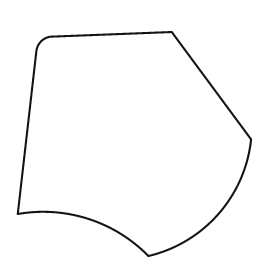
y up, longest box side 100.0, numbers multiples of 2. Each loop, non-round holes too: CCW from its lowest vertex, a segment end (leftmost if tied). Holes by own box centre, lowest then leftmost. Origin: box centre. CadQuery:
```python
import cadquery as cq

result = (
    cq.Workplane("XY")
    .moveTo(6.0, -48.0)
    .threePointArc((36.0, -30.0), (50.0, 2.0))
    .lineTo(16.0, 48.0)
    .lineTo(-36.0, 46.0)
    .threePointArc((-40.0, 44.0), (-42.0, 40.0))
    .lineTo(-50.0, -30.0)
    .threePointArc((-20.0, -32.0), (6.0, -48.0))
    .close()
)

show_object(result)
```